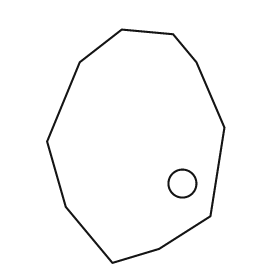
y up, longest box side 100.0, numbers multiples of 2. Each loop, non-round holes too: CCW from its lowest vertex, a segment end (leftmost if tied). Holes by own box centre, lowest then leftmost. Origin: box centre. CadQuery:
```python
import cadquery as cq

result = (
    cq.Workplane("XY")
    .moveTo(-10.0, -50.0)
    .lineTo(10.0, -44.0)
    .lineTo(32.0, -30.0)
    .lineTo(38.0, 8.0)
    .lineTo(26.0, 36.0)
    .lineTo(16.0, 48.0)
    .lineTo(-6.0, 50.0)
    .lineTo(-24.0, 36.0)
    .lineTo(-38.0, 2.0)
    .lineTo(-30.0, -26.0)
    .close()
    .moveTo(20.0, -16.0)
    .circle(6.0)
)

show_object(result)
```